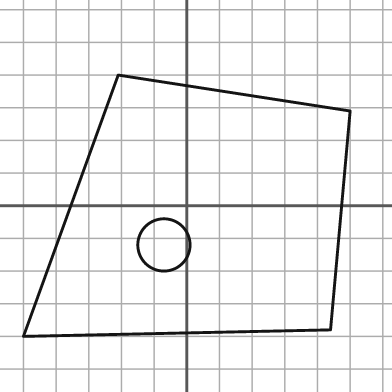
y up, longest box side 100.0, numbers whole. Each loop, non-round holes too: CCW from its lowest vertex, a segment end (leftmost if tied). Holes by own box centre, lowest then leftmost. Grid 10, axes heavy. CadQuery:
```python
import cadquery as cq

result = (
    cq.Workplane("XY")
    .moveTo(-50.0, -40.0)
    .lineTo(44.0, -38.0)
    .lineTo(50.0, 29.0)
    .lineTo(-21.0, 40.0)
    .close()
    .moveTo(-7.0, -12.0)
    .circle(8.0)
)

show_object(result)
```